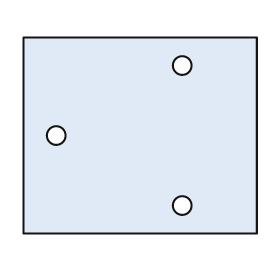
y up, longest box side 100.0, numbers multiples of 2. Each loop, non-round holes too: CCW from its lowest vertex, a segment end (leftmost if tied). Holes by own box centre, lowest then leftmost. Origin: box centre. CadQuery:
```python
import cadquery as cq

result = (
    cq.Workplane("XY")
    .moveTo(-50.0, -42.0)
    .lineTo(50.0, -42.0)
    .lineTo(50.0, 42.0)
    .lineTo(-50.0, 42.0)
    .close()
    .moveTo(18.0, -30.0)
    .circle(4.0)
    .moveTo(-36.0, 0.0)
    .circle(4.0)
    .moveTo(18.0, 30.0)
    .circle(4.0)
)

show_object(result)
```